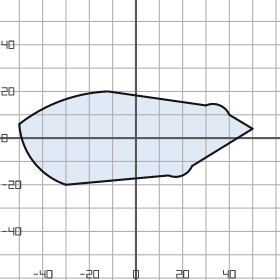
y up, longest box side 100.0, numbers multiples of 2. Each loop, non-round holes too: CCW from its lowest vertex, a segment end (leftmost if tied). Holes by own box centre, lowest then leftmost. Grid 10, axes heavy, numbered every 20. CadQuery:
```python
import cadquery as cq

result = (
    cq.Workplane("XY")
    .moveTo(-30.0, -20.0)
    .lineTo(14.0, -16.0)
    .threePointArc((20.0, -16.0), (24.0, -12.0))
    .lineTo(50.0, 4.0)
    .lineTo(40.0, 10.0)
    .threePointArc((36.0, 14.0), (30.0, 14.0))
    .lineTo(-12.0, 20.0)
    .threePointArc((-32.0, 16.0), (-50.0, 6.0))
    .threePointArc((-44.0, -10.0), (-30.0, -20.0))
    .close()
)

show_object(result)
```